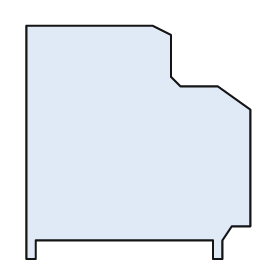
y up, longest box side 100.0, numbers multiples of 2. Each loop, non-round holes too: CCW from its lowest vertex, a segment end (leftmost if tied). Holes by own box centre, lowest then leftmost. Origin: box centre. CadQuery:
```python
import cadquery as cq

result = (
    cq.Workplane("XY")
    .moveTo(-48.0, -50.0)
    .lineTo(-44.0, -50.0)
    .lineTo(-44.0, -42.0)
    .lineTo(32.0, -42.0)
    .lineTo(32.0, -50.0)
    .lineTo(36.0, -50.0)
    .lineTo(36.0, -42.0)
    .lineTo(40.0, -36.0)
    .lineTo(48.0, -36.0)
    .lineTo(48.0, 14.0)
    .lineTo(34.0, 24.0)
    .lineTo(18.0, 24.0)
    .lineTo(14.0, 28.0)
    .lineTo(14.0, 46.0)
    .lineTo(6.0, 50.0)
    .lineTo(-48.0, 50.0)
    .close()
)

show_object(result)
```